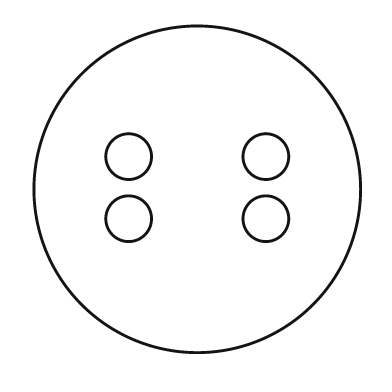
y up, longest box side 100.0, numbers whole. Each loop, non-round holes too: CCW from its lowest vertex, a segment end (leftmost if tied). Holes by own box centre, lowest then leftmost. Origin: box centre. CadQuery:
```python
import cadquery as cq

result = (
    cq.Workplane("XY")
    .moveTo(0.0, 0.0)
    .circle(50.0)
    .moveTo(-21.0, -9.0)
    .circle(7.0)
    .moveTo(21.0, -9.0)
    .circle(7.0)
    .moveTo(-21.0, 10.0)
    .circle(7.0)
    .moveTo(21.0, 10.0)
    .circle(7.0)
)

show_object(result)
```